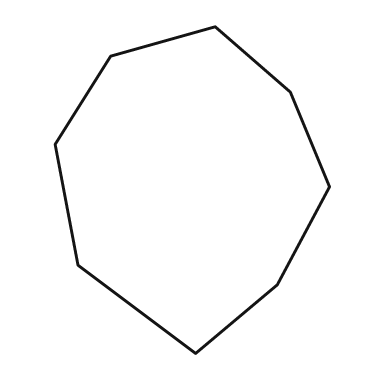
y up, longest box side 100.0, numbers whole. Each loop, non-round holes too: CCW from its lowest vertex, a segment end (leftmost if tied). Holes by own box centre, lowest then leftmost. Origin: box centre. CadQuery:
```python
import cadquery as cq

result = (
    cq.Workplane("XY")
    .moveTo(1.0, -50.0)
    .lineTo(26.0, -29.0)
    .lineTo(42.0, 1.0)
    .lineTo(30.0, 30.0)
    .lineTo(7.0, 50.0)
    .lineTo(-25.0, 41.0)
    .lineTo(-42.0, 14.0)
    .lineTo(-35.0, -23.0)
    .close()
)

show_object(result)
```